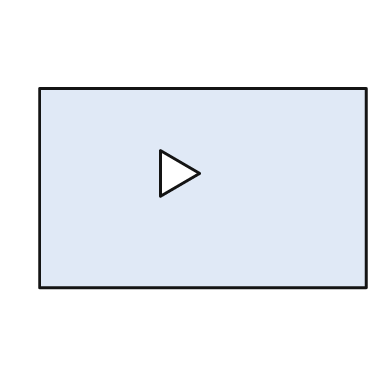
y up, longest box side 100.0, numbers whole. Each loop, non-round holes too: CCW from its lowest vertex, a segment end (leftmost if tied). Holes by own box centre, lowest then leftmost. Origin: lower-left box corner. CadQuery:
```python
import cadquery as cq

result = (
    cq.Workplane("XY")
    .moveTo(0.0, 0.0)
    .lineTo(100.0, 0.0)
    .lineTo(100.0, 61.0)
    .lineTo(0.0, 61.0)
    .close()
    .moveTo(37.0, 28.0)
    .lineTo(49.0, 35.0)
    .lineTo(37.0, 42.0)
    .close()
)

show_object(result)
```